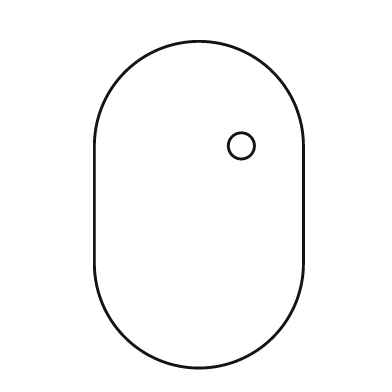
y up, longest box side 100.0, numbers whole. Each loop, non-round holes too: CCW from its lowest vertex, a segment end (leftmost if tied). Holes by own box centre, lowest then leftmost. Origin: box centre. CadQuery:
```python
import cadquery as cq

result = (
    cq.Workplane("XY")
    .moveTo(-32.0, -18.0)
    .threePointArc((0.0, -50.0), (32.0, -18.0))
    .lineTo(32.0, 18.0)
    .threePointArc((0.0, 50.0), (-32.0, 18.0))
    .close()
    .moveTo(13.0, 18.0)
    .circle(4.0)
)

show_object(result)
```